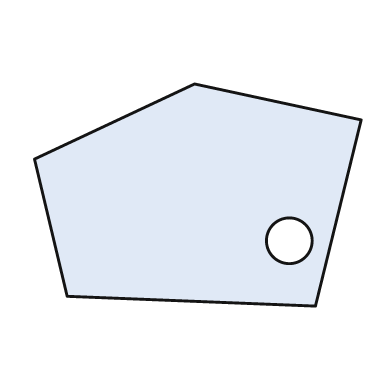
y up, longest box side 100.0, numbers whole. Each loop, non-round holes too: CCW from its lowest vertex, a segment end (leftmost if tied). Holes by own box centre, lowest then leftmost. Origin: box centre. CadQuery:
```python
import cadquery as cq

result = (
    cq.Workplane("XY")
    .moveTo(36.0, -34.0)
    .lineTo(50.0, 23.0)
    .lineTo(-1.0, 34.0)
    .lineTo(-50.0, 11.0)
    .lineTo(-40.0, -31.0)
    .close()
    .moveTo(28.0, -14.0)
    .circle(7.0)
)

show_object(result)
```